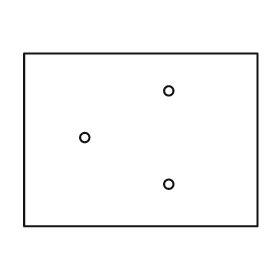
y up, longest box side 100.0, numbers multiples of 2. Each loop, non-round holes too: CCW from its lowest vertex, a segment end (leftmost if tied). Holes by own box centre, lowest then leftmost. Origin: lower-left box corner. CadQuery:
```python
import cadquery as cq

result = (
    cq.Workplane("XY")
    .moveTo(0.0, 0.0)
    .lineTo(100.0, 0.0)
    .lineTo(100.0, 74.0)
    .lineTo(0.0, 74.0)
    .close()
    .moveTo(62.0, 18.0)
    .circle(2.0)
    .moveTo(26.0, 38.0)
    .circle(2.0)
    .moveTo(62.0, 58.0)
    .circle(2.0)
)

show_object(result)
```